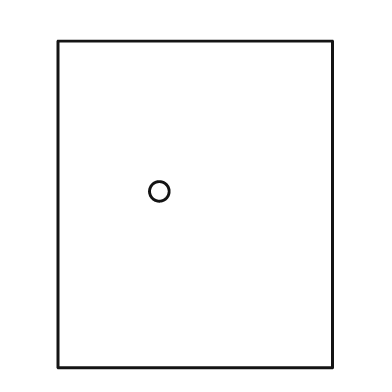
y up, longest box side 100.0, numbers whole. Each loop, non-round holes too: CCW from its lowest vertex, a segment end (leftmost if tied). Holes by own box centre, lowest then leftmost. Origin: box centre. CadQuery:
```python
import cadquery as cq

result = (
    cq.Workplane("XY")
    .moveTo(-42.0, -50.0)
    .lineTo(42.0, -50.0)
    .lineTo(42.0, 50.0)
    .lineTo(-42.0, 50.0)
    .close()
    .moveTo(-11.0, 4.0)
    .circle(3.0)
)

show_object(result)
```